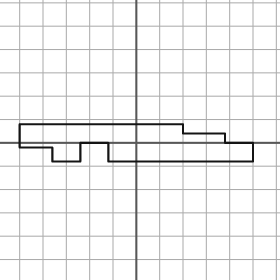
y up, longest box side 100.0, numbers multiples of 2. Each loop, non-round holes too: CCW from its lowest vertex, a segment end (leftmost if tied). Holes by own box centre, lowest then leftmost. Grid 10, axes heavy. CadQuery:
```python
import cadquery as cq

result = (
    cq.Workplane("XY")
    .moveTo(-36.0, -8.0)
    .lineTo(-24.0, -8.0)
    .lineTo(-24.0, 0.0)
    .lineTo(-12.0, 0.0)
    .lineTo(-12.0, -8.0)
    .lineTo(50.0, -8.0)
    .lineTo(50.0, 0.0)
    .lineTo(38.0, 0.0)
    .lineTo(38.0, 4.0)
    .lineTo(20.0, 4.0)
    .lineTo(20.0, 8.0)
    .lineTo(-50.0, 8.0)
    .lineTo(-50.0, -2.0)
    .lineTo(-36.0, -2.0)
    .close()
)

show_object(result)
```